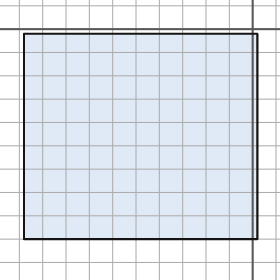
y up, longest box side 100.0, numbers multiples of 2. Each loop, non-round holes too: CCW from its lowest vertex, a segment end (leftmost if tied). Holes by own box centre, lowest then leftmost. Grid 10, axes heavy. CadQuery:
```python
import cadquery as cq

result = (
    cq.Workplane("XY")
    .moveTo(-98.0, -90.0)
    .lineTo(2.0, -90.0)
    .lineTo(2.0, -2.0)
    .lineTo(-98.0, -2.0)
    .close()
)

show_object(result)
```